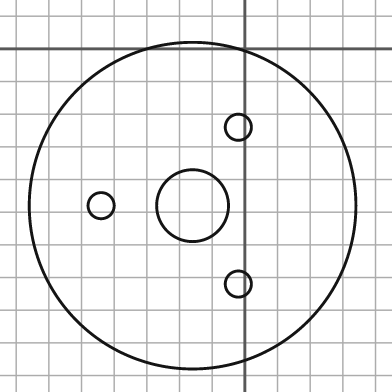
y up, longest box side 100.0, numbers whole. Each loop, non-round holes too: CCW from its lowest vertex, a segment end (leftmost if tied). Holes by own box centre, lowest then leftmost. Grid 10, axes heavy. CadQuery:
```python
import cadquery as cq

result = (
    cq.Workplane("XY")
    .moveTo(-16.0, -48.0)
    .circle(50.0)
    .moveTo(-2.0, -72.0)
    .circle(4.0)
    .moveTo(-44.0, -48.0)
    .circle(4.0)
    .moveTo(-16.0, -48.0)
    .circle(11.0)
    .moveTo(-2.0, -24.0)
    .circle(4.0)
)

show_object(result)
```